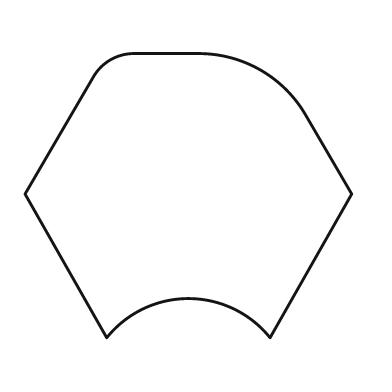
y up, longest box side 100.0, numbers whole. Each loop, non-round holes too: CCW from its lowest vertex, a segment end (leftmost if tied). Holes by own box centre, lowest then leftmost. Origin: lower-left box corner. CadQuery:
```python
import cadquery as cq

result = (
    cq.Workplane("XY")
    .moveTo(25.0, 0.0)
    .threePointArc((50.0, 12.0), (75.0, 0.0))
    .lineTo(100.0, 44.0)
    .lineTo(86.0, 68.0)
    .threePointArc((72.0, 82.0), (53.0, 87.0))
    .lineTo(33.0, 87.0)
    .threePointArc((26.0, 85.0), (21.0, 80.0))
    .lineTo(0.0, 44.0)
    .close()
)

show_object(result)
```